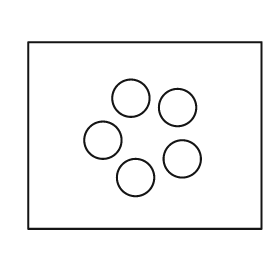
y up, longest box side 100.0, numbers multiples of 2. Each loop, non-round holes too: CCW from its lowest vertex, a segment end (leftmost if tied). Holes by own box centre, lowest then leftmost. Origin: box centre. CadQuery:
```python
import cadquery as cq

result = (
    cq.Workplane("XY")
    .moveTo(-50.0, -40.0)
    .lineTo(50.0, -40.0)
    .lineTo(50.0, 40.0)
    .lineTo(-50.0, 40.0)
    .close()
    .moveTo(-4.0, -18.0)
    .circle(8.0)
    .moveTo(16.0, -10.0)
    .circle(8.0)
    .moveTo(-18.0, -2.0)
    .circle(8.0)
    .moveTo(14.0, 12.0)
    .circle(8.0)
    .moveTo(-6.0, 16.0)
    .circle(8.0)
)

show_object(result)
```